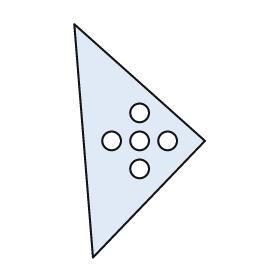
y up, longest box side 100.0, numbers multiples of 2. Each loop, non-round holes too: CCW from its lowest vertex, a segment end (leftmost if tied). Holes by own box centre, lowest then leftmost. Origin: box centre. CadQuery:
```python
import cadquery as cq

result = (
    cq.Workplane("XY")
    .moveTo(-20.0, -50.0)
    .lineTo(28.0, 0.0)
    .lineTo(-28.0, 50.0)
    .close()
    .moveTo(0.0, -12.0)
    .circle(4.0)
    .moveTo(-12.0, 0.0)
    .circle(4.0)
    .moveTo(0.0, 0.0)
    .circle(4.0)
    .moveTo(12.0, 0.0)
    .circle(4.0)
    .moveTo(0.0, 12.0)
    .circle(4.0)
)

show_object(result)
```